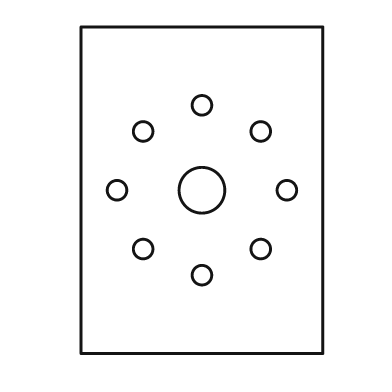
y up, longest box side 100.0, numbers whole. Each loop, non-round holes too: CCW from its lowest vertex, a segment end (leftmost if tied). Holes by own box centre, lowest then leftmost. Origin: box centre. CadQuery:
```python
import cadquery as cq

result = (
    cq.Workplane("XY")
    .moveTo(-37.0, -50.0)
    .lineTo(37.0, -50.0)
    .lineTo(37.0, 50.0)
    .lineTo(-37.0, 50.0)
    .close()
    .moveTo(0.0, -26.0)
    .circle(3.0)
    .moveTo(-18.0, -18.0)
    .circle(3.0)
    .moveTo(18.0, -18.0)
    .circle(3.0)
    .moveTo(-26.0, 0.0)
    .circle(3.0)
    .moveTo(0.0, 0.0)
    .circle(7.0)
    .moveTo(26.0, 0.0)
    .circle(3.0)
    .moveTo(-18.0, 18.0)
    .circle(3.0)
    .moveTo(18.0, 18.0)
    .circle(3.0)
    .moveTo(0.0, 26.0)
    .circle(3.0)
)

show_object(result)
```